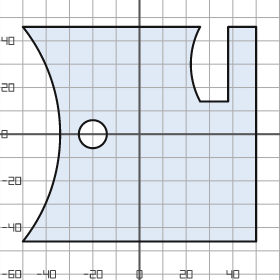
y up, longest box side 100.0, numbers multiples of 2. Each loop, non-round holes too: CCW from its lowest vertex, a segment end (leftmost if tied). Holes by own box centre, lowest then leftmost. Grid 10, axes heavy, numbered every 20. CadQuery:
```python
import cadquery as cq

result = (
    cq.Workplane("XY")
    .moveTo(-50.0, -46.0)
    .lineTo(50.0, -46.0)
    .lineTo(50.0, 46.0)
    .lineTo(38.0, 46.0)
    .lineTo(38.0, 14.0)
    .lineTo(26.0, 14.0)
    .threePointArc((22.0, 30.0), (26.0, 46.0))
    .lineTo(-50.0, 46.0)
    .threePointArc((-34.0, 0.0), (-50.0, -46.0))
    .close()
    .moveTo(-20.0, 0.0)
    .circle(6.0)
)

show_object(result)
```